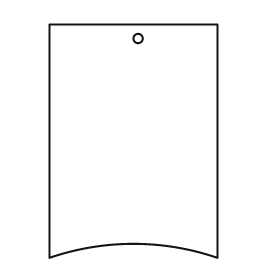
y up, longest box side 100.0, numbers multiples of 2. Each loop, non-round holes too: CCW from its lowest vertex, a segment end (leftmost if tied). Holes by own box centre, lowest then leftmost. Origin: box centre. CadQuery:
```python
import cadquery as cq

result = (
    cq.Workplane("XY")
    .moveTo(-36.0, -50.0)
    .threePointArc((0.0, -44.0), (36.0, -50.0))
    .lineTo(36.0, 50.0)
    .lineTo(-36.0, 50.0)
    .close()
    .moveTo(2.0, 44.0)
    .circle(2.0)
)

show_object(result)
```